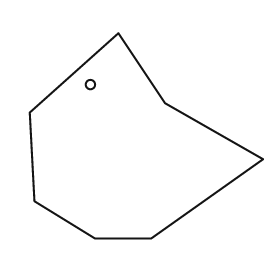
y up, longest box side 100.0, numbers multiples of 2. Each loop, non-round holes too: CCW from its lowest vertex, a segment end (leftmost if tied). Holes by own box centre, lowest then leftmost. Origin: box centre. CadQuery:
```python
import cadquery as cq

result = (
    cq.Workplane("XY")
    .moveTo(-22.0, -44.0)
    .lineTo(2.0, -44.0)
    .lineTo(50.0, -10.0)
    .lineTo(8.0, 14.0)
    .lineTo(-12.0, 44.0)
    .lineTo(-50.0, 10.0)
    .lineTo(-48.0, -28.0)
    .close()
    .moveTo(-24.0, 22.0)
    .circle(2.0)
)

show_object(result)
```